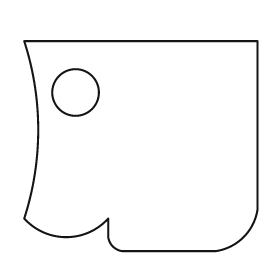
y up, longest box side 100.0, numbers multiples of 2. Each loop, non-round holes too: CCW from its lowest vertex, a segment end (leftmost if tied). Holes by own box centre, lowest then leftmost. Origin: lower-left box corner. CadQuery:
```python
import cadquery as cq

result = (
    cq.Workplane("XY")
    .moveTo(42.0, 0.0)
    .lineTo(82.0, 0.0)
    .threePointArc((94.0, 6.0), (100.0, 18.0))
    .lineTo(100.0, 90.0)
    .lineTo(0.0, 90.0)
    .threePointArc((6.0, 52.0), (0.0, 14.0))
    .threePointArc((18.0, 6.0), (36.0, 14.0))
    .lineTo(36.0, 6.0)
    .threePointArc((38.0, 2.0), (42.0, 0.0))
    .close()
    .moveTo(22.0, 68.0)
    .circle(10.0)
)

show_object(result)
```